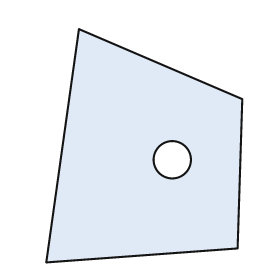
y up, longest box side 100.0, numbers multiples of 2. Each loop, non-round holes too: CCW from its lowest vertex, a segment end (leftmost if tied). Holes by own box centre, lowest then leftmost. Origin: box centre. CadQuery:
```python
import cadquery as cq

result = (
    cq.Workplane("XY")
    .moveTo(-42.0, -50.0)
    .lineTo(40.0, -44.0)
    .lineTo(42.0, 20.0)
    .lineTo(-28.0, 50.0)
    .close()
    .moveTo(12.0, -6.0)
    .circle(8.0)
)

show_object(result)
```